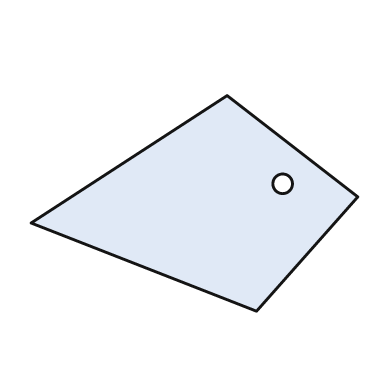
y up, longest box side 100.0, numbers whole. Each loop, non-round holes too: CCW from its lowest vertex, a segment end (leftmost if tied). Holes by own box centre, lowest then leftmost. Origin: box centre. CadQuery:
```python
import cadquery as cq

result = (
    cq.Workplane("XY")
    .moveTo(19.0, -33.0)
    .lineTo(50.0, 2.0)
    .lineTo(10.0, 33.0)
    .lineTo(-50.0, -6.0)
    .close()
    .moveTo(27.0, 6.0)
    .circle(3.0)
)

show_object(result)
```